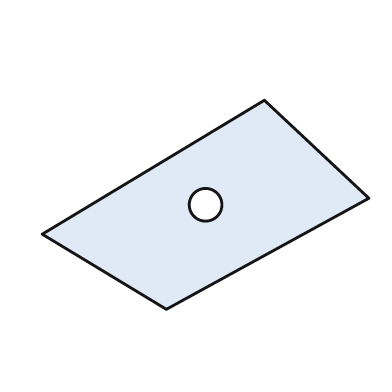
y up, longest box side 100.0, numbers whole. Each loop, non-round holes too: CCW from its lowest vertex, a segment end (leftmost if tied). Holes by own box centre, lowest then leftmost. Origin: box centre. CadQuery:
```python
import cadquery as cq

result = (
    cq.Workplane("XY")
    .moveTo(-12.0, -32.0)
    .lineTo(50.0, 2.0)
    .lineTo(18.0, 32.0)
    .lineTo(-50.0, -9.0)
    .close()
    .moveTo(0.0, 0.0)
    .circle(5.0)
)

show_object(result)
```